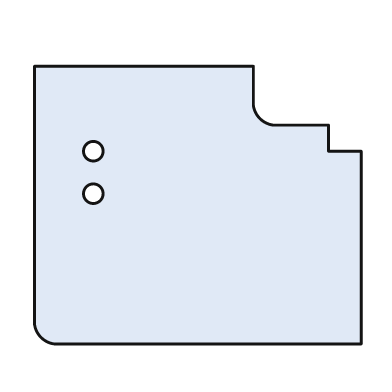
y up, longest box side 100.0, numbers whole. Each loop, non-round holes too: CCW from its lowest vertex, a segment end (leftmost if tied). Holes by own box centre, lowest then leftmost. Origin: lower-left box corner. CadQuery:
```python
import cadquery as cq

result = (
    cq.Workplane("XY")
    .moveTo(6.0, 0.0)
    .lineTo(100.0, 0.0)
    .lineTo(100.0, 59.0)
    .lineTo(90.0, 59.0)
    .lineTo(90.0, 67.0)
    .lineTo(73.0, 67.0)
    .threePointArc((69.0, 69.0), (67.0, 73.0))
    .lineTo(67.0, 85.0)
    .lineTo(0.0, 85.0)
    .lineTo(0.0, 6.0)
    .threePointArc((2.0, 2.0), (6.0, 0.0))
    .close()
    .moveTo(18.0, 46.0)
    .circle(3.0)
    .moveTo(18.0, 59.0)
    .circle(3.0)
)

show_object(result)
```